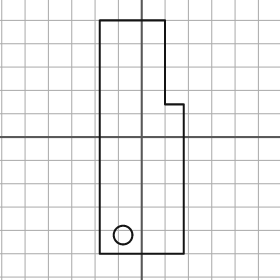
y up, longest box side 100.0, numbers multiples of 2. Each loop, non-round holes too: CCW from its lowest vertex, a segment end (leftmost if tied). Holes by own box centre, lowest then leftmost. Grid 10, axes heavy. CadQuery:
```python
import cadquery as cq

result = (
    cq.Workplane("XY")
    .moveTo(-18.0, -50.0)
    .lineTo(18.0, -50.0)
    .lineTo(18.0, 14.0)
    .lineTo(10.0, 14.0)
    .lineTo(10.0, 50.0)
    .lineTo(-18.0, 50.0)
    .close()
    .moveTo(-8.0, -42.0)
    .circle(4.0)
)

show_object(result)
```